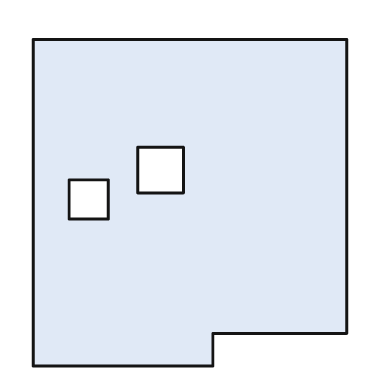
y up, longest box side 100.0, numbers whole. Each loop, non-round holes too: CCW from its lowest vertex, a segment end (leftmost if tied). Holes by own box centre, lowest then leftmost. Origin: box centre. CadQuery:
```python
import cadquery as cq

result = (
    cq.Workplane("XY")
    .moveTo(-48.0, -50.0)
    .lineTo(7.0, -50.0)
    .lineTo(7.0, -40.0)
    .lineTo(48.0, -40.0)
    .lineTo(48.0, 50.0)
    .lineTo(-48.0, 50.0)
    .close()
    .moveTo(-37.0, -5.0)
    .lineTo(-25.0, -5.0)
    .lineTo(-25.0, 7.0)
    .lineTo(-37.0, 7.0)
    .close()
    .moveTo(-16.0, 3.0)
    .lineTo(-2.0, 3.0)
    .lineTo(-2.0, 17.0)
    .lineTo(-16.0, 17.0)
    .close()
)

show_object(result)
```